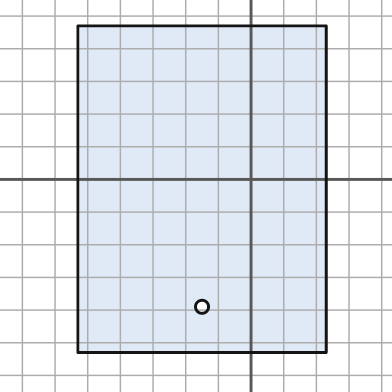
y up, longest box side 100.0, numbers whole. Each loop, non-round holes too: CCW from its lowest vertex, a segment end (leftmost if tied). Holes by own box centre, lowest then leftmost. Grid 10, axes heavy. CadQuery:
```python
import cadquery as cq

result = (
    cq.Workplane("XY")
    .moveTo(-53.0, -53.0)
    .lineTo(23.0, -53.0)
    .lineTo(23.0, 47.0)
    .lineTo(-53.0, 47.0)
    .close()
    .moveTo(-15.0, -39.0)
    .circle(2.0)
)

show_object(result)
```